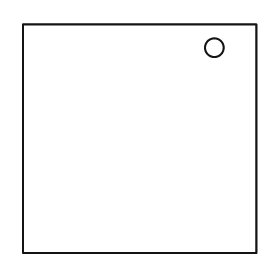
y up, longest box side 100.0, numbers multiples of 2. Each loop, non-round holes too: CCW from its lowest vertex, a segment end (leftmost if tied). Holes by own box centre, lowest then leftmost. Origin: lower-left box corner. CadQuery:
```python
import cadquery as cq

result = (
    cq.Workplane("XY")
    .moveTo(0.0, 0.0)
    .lineTo(100.0, 0.0)
    .lineTo(100.0, 98.0)
    .lineTo(0.0, 98.0)
    .close()
    .moveTo(82.0, 88.0)
    .circle(4.0)
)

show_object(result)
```